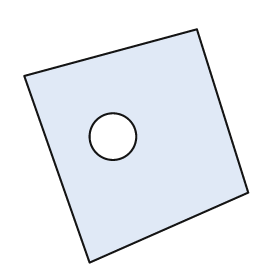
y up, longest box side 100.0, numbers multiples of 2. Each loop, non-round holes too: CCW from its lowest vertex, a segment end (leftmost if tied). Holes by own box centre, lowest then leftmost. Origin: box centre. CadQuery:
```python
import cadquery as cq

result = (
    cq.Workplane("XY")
    .moveTo(-20.0, -50.0)
    .lineTo(48.0, -20.0)
    .lineTo(26.0, 50.0)
    .lineTo(-48.0, 30.0)
    .close()
    .moveTo(-10.0, 4.0)
    .circle(10.0)
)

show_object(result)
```